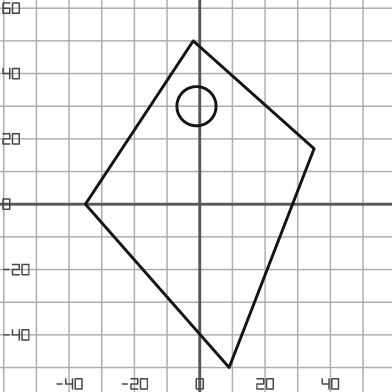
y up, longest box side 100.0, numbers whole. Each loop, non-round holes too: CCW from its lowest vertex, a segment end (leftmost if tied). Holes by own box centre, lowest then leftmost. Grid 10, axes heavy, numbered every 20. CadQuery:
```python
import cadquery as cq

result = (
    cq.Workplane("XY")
    .moveTo(9.0, -50.0)
    .lineTo(35.0, 17.0)
    .lineTo(-2.0, 50.0)
    .lineTo(-35.0, 0.0)
    .close()
    .moveTo(-1.0, 30.0)
    .circle(6.0)
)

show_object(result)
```